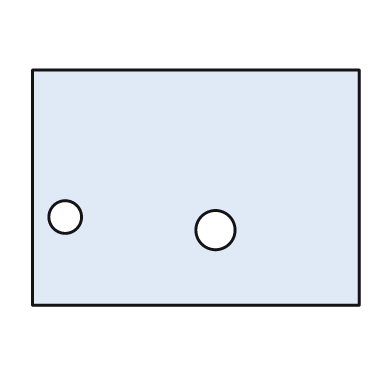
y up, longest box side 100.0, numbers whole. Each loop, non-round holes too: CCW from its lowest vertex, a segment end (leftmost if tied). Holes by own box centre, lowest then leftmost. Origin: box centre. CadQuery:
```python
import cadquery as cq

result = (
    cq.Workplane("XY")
    .moveTo(-50.0, -36.0)
    .lineTo(50.0, -36.0)
    .lineTo(50.0, 36.0)
    .lineTo(-50.0, 36.0)
    .close()
    .moveTo(6.0, -13.0)
    .circle(6.0)
    .moveTo(-40.0, -9.0)
    .circle(5.0)
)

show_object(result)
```